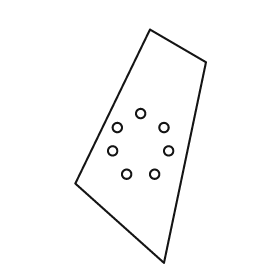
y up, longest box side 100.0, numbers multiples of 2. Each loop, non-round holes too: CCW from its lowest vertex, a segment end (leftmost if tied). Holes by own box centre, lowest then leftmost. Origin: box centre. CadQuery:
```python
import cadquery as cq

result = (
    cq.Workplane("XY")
    .moveTo(10.0, -50.0)
    .lineTo(28.0, 36.0)
    .lineTo(4.0, 50.0)
    .lineTo(-28.0, -16.0)
    .close()
    .moveTo(-6.0, -12.0)
    .circle(2.0)
    .moveTo(6.0, -12.0)
    .circle(2.0)
    .moveTo(-12.0, -2.0)
    .circle(2.0)
    .moveTo(12.0, -2.0)
    .circle(2.0)
    .moveTo(-10.0, 8.0)
    .circle(2.0)
    .moveTo(10.0, 8.0)
    .circle(2.0)
    .moveTo(0.0, 14.0)
    .circle(2.0)
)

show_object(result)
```